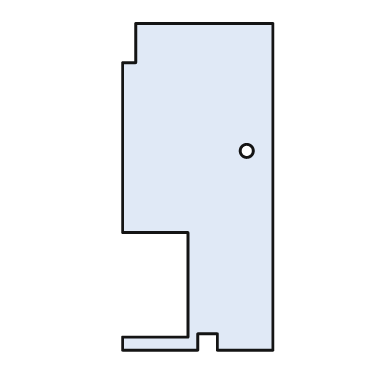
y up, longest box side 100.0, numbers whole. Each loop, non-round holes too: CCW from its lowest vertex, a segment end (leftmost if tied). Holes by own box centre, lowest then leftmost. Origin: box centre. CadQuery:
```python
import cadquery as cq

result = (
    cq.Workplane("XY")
    .moveTo(-23.0, -50.0)
    .lineTo(0.0, -50.0)
    .lineTo(0.0, -45.0)
    .lineTo(6.0, -45.0)
    .lineTo(6.0, -50.0)
    .lineTo(23.0, -50.0)
    .lineTo(23.0, 50.0)
    .lineTo(-19.0, 50.0)
    .lineTo(-19.0, 38.0)
    .lineTo(-23.0, 38.0)
    .lineTo(-23.0, -14.0)
    .lineTo(-3.0, -14.0)
    .lineTo(-3.0, -46.0)
    .lineTo(-23.0, -46.0)
    .close()
    .moveTo(15.0, 11.0)
    .circle(2.0)
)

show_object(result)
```